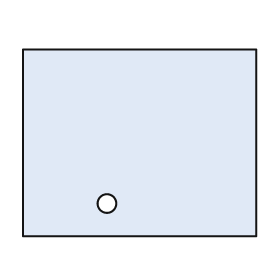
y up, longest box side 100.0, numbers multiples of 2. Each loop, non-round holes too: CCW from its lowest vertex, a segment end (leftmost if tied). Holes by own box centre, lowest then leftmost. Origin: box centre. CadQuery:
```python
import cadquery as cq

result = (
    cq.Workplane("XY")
    .moveTo(-50.0, -40.0)
    .lineTo(50.0, -40.0)
    .lineTo(50.0, 40.0)
    .lineTo(-50.0, 40.0)
    .close()
    .moveTo(-14.0, -26.0)
    .circle(4.0)
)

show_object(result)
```